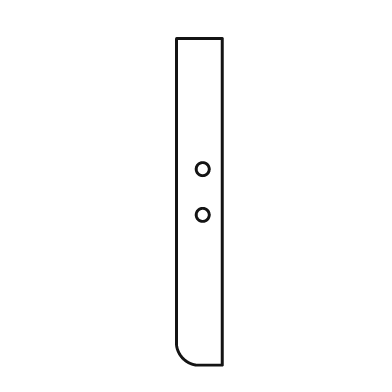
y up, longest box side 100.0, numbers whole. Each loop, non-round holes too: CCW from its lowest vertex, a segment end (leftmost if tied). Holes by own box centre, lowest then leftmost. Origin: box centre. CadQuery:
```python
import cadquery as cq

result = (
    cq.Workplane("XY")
    .moveTo(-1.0, -50.0)
    .lineTo(7.0, -50.0)
    .lineTo(7.0, 50.0)
    .lineTo(-7.0, 50.0)
    .lineTo(-7.0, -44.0)
    .threePointArc((-5.0, -48.0), (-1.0, -50.0))
    .close()
    .moveTo(1.0, -4.0)
    .circle(2.0)
    .moveTo(1.0, 10.0)
    .circle(2.0)
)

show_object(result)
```